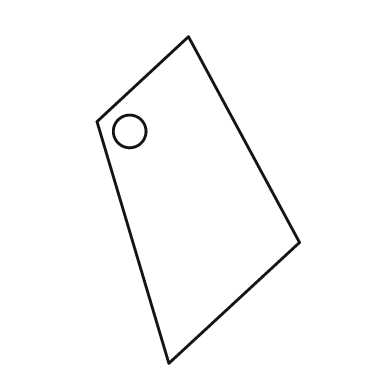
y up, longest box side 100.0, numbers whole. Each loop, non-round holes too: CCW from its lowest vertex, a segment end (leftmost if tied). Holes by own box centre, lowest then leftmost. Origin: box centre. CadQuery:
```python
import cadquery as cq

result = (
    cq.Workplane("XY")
    .moveTo(-9.0, -50.0)
    .lineTo(31.0, -13.0)
    .lineTo(-3.0, 50.0)
    .lineTo(-31.0, 24.0)
    .close()
    .moveTo(-21.0, 21.0)
    .circle(5.0)
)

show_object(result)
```